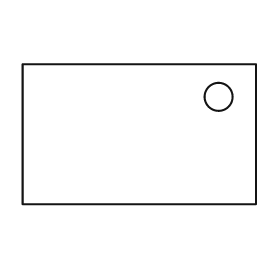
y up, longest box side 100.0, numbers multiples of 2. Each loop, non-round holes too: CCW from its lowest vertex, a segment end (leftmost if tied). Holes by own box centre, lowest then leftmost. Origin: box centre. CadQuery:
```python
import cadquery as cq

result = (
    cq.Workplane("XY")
    .moveTo(-50.0, -30.0)
    .lineTo(50.0, -30.0)
    .lineTo(50.0, 30.0)
    .lineTo(-50.0, 30.0)
    .close()
    .moveTo(34.0, 16.0)
    .circle(6.0)
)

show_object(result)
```